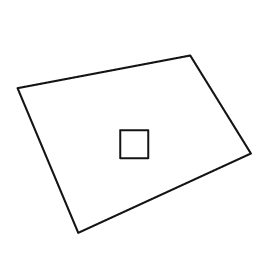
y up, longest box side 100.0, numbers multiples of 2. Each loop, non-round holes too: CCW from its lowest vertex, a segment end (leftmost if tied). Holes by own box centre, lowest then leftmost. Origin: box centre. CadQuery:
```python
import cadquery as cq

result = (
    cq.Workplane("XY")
    .moveTo(-24.0, -38.0)
    .lineTo(50.0, -4.0)
    .lineTo(24.0, 38.0)
    .lineTo(-50.0, 24.0)
    .close()
    .moveTo(-6.0, -6.0)
    .lineTo(6.0, -6.0)
    .lineTo(6.0, 6.0)
    .lineTo(-6.0, 6.0)
    .close()
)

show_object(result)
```